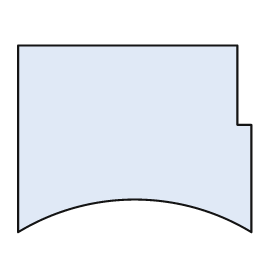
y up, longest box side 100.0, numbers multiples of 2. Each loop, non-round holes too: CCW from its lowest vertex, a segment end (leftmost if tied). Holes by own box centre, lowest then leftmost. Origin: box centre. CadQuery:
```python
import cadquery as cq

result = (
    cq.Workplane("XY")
    .moveTo(-50.0, -40.0)
    .threePointArc((0.0, -26.0), (50.0, -40.0))
    .lineTo(50.0, 6.0)
    .lineTo(44.0, 6.0)
    .lineTo(44.0, 40.0)
    .lineTo(-50.0, 40.0)
    .close()
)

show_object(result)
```